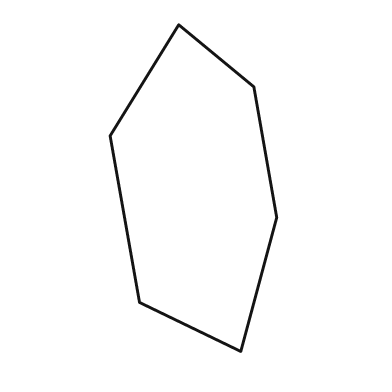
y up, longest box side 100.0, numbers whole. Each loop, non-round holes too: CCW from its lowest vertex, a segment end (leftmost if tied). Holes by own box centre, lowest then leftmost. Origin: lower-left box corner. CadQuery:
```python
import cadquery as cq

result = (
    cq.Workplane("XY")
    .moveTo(40.0, 0.0)
    .lineTo(51.0, 41.0)
    .lineTo(44.0, 81.0)
    .lineTo(21.0, 100.0)
    .lineTo(0.0, 66.0)
    .lineTo(9.0, 15.0)
    .close()
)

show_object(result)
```